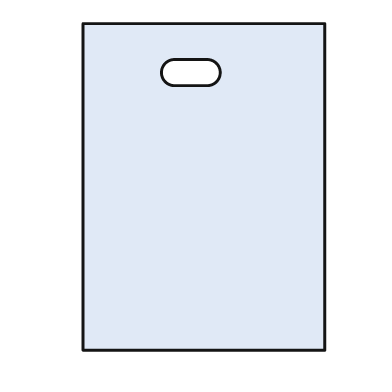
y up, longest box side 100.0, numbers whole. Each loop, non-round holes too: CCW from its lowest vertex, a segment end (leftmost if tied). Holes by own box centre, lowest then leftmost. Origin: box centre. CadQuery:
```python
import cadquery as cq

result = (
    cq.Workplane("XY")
    .moveTo(-37.0, -50.0)
    .lineTo(37.0, -50.0)
    .lineTo(37.0, 50.0)
    .lineTo(-37.0, 50.0)
    .close()
    .moveTo(-9.0, 31.0)
    .lineTo(1.0, 31.0)
    .threePointArc((5.0, 35.0), (1.0, 39.0))
    .lineTo(-9.0, 39.0)
    .threePointArc((-13.0, 35.0), (-9.0, 31.0))
    .close()
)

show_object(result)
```